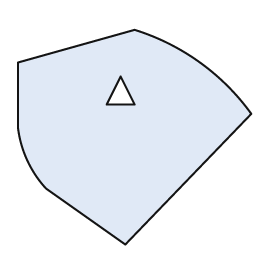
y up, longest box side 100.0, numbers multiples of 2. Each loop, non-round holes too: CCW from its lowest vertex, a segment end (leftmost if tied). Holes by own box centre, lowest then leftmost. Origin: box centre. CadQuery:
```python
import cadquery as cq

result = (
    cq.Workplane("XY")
    .moveTo(-4.0, -46.0)
    .lineTo(50.0, 10.0)
    .threePointArc((28.0, 32.0), (0.0, 46.0))
    .lineTo(-50.0, 32.0)
    .lineTo(-50.0, 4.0)
    .threePointArc((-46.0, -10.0), (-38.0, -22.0))
    .close()
    .moveTo(-12.0, 14.0)
    .lineTo(0.0, 14.0)
    .lineTo(-6.0, 26.0)
    .close()
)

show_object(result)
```